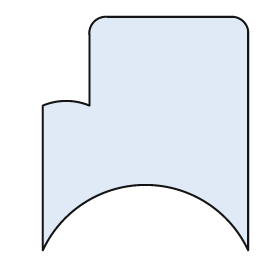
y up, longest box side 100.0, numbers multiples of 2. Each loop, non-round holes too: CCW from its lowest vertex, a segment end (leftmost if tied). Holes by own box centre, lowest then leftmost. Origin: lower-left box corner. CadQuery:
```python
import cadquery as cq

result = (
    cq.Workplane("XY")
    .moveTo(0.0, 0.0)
    .threePointArc((44.0, 28.0), (88.0, 0.0))
    .lineTo(88.0, 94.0)
    .threePointArc((86.0, 98.0), (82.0, 100.0))
    .lineTo(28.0, 100.0)
    .threePointArc((22.0, 98.0), (20.0, 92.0))
    .lineTo(20.0, 62.0)
    .threePointArc((10.0, 64.0), (0.0, 62.0))
    .close()
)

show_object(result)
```